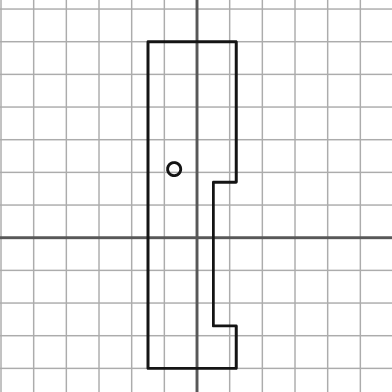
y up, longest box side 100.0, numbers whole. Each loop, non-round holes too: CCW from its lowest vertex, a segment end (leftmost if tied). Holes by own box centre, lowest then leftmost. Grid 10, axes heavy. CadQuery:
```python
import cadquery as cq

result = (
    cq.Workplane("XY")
    .moveTo(-15.0, -40.0)
    .lineTo(12.0, -40.0)
    .lineTo(12.0, -27.0)
    .lineTo(5.0, -27.0)
    .lineTo(5.0, 17.0)
    .lineTo(12.0, 17.0)
    .lineTo(12.0, 60.0)
    .lineTo(-15.0, 60.0)
    .close()
    .moveTo(-7.0, 21.0)
    .circle(2.0)
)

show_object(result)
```